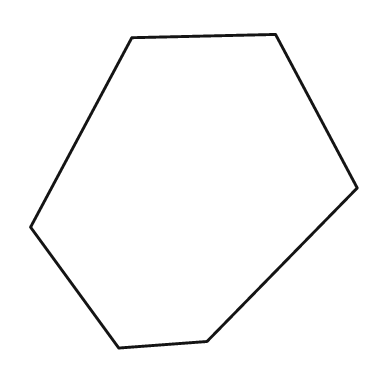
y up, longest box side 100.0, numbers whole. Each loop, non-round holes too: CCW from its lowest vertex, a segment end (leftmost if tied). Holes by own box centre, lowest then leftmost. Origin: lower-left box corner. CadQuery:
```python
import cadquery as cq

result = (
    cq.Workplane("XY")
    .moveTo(27.0, 0.0)
    .lineTo(54.0, 2.0)
    .lineTo(100.0, 49.0)
    .lineTo(75.0, 96.0)
    .lineTo(31.0, 95.0)
    .lineTo(0.0, 37.0)
    .close()
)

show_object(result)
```